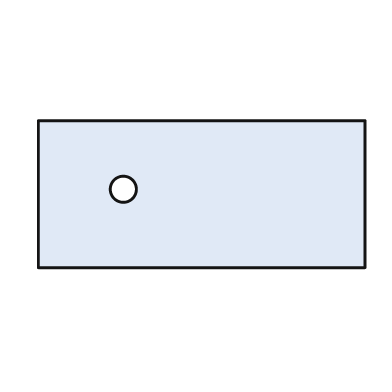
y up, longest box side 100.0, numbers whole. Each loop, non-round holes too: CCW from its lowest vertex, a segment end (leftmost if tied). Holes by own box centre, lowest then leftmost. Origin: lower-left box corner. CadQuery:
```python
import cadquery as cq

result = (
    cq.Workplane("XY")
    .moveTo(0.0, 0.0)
    .lineTo(100.0, 0.0)
    .lineTo(100.0, 45.0)
    .lineTo(0.0, 45.0)
    .close()
    .moveTo(26.0, 24.0)
    .circle(4.0)
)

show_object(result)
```